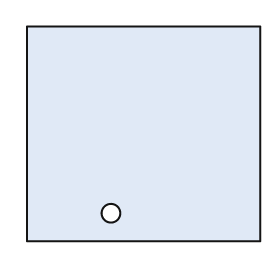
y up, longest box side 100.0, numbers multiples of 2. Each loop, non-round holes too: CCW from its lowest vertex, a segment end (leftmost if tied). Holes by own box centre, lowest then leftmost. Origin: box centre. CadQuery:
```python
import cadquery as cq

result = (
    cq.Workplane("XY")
    .moveTo(-50.0, -46.0)
    .lineTo(50.0, -46.0)
    .lineTo(50.0, 46.0)
    .lineTo(-50.0, 46.0)
    .close()
    .moveTo(-14.0, -34.0)
    .circle(4.0)
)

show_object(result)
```